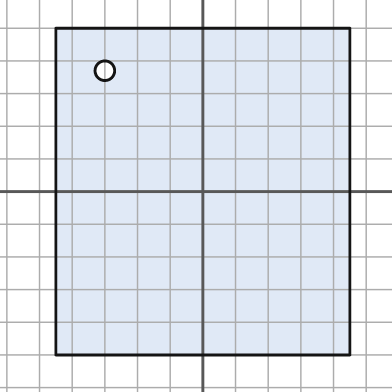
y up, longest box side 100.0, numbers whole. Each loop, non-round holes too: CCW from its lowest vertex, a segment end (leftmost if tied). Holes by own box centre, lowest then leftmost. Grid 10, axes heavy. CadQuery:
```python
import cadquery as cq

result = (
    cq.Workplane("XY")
    .moveTo(-45.0, -50.0)
    .lineTo(45.0, -50.0)
    .lineTo(45.0, 50.0)
    .lineTo(-45.0, 50.0)
    .close()
    .moveTo(-30.0, 37.0)
    .circle(3.0)
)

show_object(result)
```